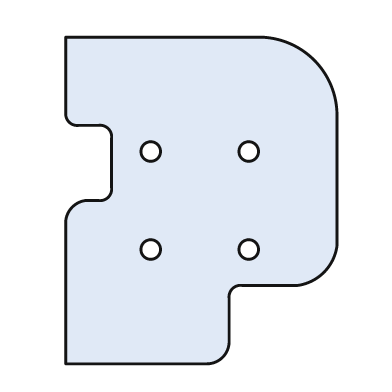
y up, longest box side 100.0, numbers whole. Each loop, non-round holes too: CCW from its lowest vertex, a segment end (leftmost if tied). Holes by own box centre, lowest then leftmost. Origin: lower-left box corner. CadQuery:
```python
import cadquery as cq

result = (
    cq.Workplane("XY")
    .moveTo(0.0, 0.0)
    .lineTo(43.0, 0.0)
    .threePointArc((48.0, 2.0), (50.0, 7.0))
    .lineTo(50.0, 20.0)
    .threePointArc((51.0, 23.0), (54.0, 24.0))
    .lineTo(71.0, 24.0)
    .threePointArc((79.0, 28.0), (83.0, 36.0))
    .lineTo(83.0, 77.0)
    .threePointArc((76.0, 93.0), (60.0, 100.0))
    .lineTo(0.0, 100.0)
    .lineTo(0.0, 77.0)
    .threePointArc((1.0, 74.0), (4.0, 73.0))
    .lineTo(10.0, 73.0)
    .threePointArc((13.0, 72.0), (14.0, 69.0))
    .lineTo(14.0, 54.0)
    .threePointArc((13.0, 51.0), (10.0, 50.0))
    .lineTo(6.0, 50.0)
    .threePointArc((2.0, 48.0), (0.0, 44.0))
    .close()
    .moveTo(26.0, 35.0)
    .circle(3.0)
    .moveTo(56.0, 35.0)
    .circle(3.0)
    .moveTo(26.0, 65.0)
    .circle(3.0)
    .moveTo(56.0, 65.0)
    .circle(3.0)
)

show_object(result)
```